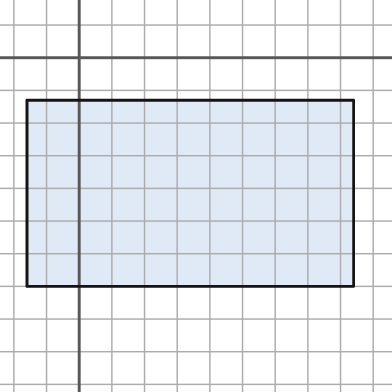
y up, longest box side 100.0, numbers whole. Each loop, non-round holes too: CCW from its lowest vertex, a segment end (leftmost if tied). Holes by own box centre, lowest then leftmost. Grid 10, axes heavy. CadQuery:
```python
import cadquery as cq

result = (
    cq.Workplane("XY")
    .moveTo(-16.0, -70.0)
    .lineTo(84.0, -70.0)
    .lineTo(84.0, -13.0)
    .lineTo(-16.0, -13.0)
    .close()
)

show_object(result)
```